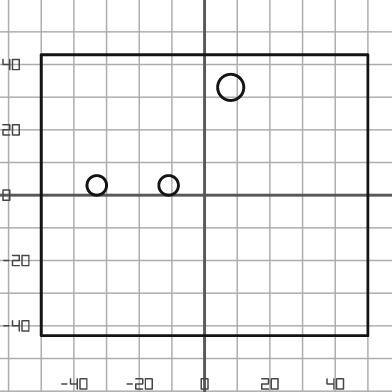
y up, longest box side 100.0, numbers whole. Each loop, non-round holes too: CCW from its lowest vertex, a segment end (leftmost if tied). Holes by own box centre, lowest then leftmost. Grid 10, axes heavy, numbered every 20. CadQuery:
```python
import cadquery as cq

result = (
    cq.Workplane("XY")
    .moveTo(-50.0, -43.0)
    .lineTo(50.0, -43.0)
    .lineTo(50.0, 43.0)
    .lineTo(-50.0, 43.0)
    .close()
    .moveTo(-33.0, 3.0)
    .circle(3.0)
    .moveTo(-11.0, 3.0)
    .circle(3.0)
    .moveTo(8.0, 33.0)
    .circle(4.0)
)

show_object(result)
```